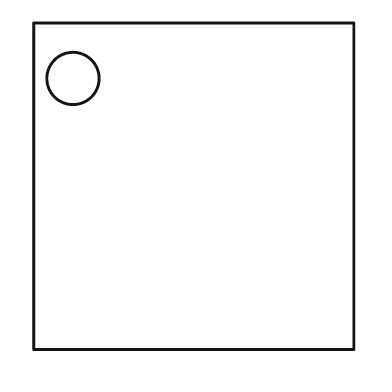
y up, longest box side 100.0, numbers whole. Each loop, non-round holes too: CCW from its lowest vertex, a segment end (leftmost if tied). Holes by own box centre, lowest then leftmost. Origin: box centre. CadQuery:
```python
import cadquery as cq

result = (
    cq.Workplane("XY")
    .moveTo(-49.0, -50.0)
    .lineTo(49.0, -50.0)
    .lineTo(49.0, 50.0)
    .lineTo(-49.0, 50.0)
    .close()
    .moveTo(-37.0, 33.0)
    .circle(8.0)
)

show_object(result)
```